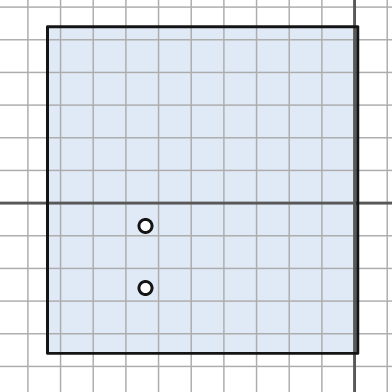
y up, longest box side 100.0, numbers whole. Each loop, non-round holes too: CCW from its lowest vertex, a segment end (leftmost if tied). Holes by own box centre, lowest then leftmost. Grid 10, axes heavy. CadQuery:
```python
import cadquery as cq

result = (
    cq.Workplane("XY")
    .moveTo(-94.0, -46.0)
    .lineTo(1.0, -46.0)
    .lineTo(1.0, 54.0)
    .lineTo(-94.0, 54.0)
    .close()
    .moveTo(-64.0, -26.0)
    .circle(2.0)
    .moveTo(-64.0, -7.0)
    .circle(2.0)
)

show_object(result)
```